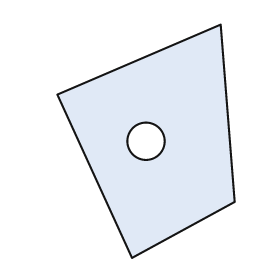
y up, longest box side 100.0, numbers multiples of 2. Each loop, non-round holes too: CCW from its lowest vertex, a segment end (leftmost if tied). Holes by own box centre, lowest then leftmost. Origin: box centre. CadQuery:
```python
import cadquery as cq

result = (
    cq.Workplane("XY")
    .moveTo(-6.0, -50.0)
    .lineTo(38.0, -26.0)
    .lineTo(32.0, 50.0)
    .lineTo(-38.0, 20.0)
    .close()
    .moveTo(0.0, 0.0)
    .circle(8.0)
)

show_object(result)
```